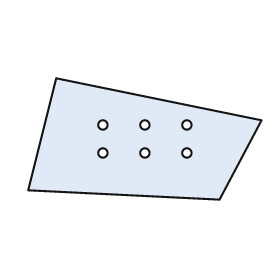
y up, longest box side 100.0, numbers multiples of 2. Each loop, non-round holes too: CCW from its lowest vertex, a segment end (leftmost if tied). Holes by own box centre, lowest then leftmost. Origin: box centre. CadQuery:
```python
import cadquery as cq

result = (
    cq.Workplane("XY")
    .moveTo(32.0, -26.0)
    .lineTo(50.0, 8.0)
    .lineTo(-38.0, 26.0)
    .lineTo(-50.0, -22.0)
    .close()
    .moveTo(-18.0, -6.0)
    .circle(2.0)
    .moveTo(0.0, -6.0)
    .circle(2.0)
    .moveTo(18.0, -6.0)
    .circle(2.0)
    .moveTo(-18.0, 6.0)
    .circle(2.0)
    .moveTo(0.0, 6.0)
    .circle(2.0)
    .moveTo(18.0, 6.0)
    .circle(2.0)
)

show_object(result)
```